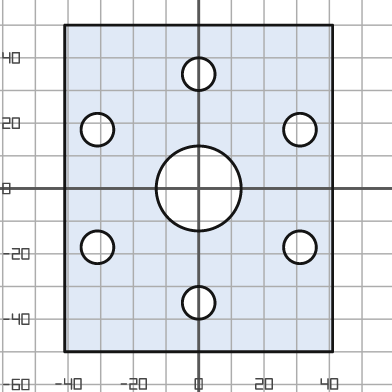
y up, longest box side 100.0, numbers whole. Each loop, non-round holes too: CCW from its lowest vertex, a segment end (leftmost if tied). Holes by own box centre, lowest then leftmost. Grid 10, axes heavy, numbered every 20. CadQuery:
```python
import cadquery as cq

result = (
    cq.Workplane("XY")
    .moveTo(-41.0, -50.0)
    .lineTo(41.0, -50.0)
    .lineTo(41.0, 50.0)
    .lineTo(-41.0, 50.0)
    .close()
    .moveTo(0.0, -35.0)
    .circle(5.0)
    .moveTo(-31.0, -18.0)
    .circle(5.0)
    .moveTo(31.0, -18.0)
    .circle(5.0)
    .moveTo(0.0, 0.0)
    .circle(13.0)
    .moveTo(-31.0, 18.0)
    .circle(5.0)
    .moveTo(31.0, 18.0)
    .circle(5.0)
    .moveTo(0.0, 35.0)
    .circle(5.0)
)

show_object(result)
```